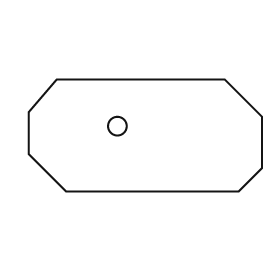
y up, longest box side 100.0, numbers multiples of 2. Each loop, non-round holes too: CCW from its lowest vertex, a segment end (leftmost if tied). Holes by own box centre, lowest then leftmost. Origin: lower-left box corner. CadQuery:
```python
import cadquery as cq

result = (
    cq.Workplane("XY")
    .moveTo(16.0, 0.0)
    .lineTo(90.0, 0.0)
    .lineTo(100.0, 10.0)
    .lineTo(100.0, 32.0)
    .lineTo(84.0, 48.0)
    .lineTo(12.0, 48.0)
    .lineTo(0.0, 34.0)
    .lineTo(0.0, 16.0)
    .close()
    .moveTo(38.0, 28.0)
    .circle(4.0)
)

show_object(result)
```